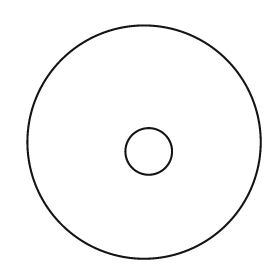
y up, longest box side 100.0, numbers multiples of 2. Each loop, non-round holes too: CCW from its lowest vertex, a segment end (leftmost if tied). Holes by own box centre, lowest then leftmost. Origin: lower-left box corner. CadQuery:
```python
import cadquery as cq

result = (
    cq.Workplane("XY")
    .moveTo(50.0, 50.0)
    .circle(50.0)
    .moveTo(52.0, 46.0)
    .circle(10.0)
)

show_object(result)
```